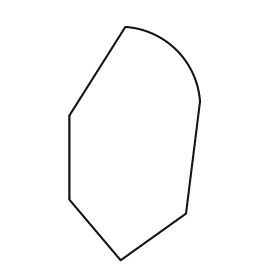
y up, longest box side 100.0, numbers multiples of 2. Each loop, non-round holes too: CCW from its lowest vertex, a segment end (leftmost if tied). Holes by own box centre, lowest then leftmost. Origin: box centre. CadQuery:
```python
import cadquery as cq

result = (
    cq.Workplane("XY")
    .moveTo(-6.0, -50.0)
    .lineTo(22.0, -30.0)
    .lineTo(28.0, 18.0)
    .threePointArc((18.0, 40.0), (-4.0, 50.0))
    .lineTo(-28.0, 12.0)
    .lineTo(-28.0, -24.0)
    .close()
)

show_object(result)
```